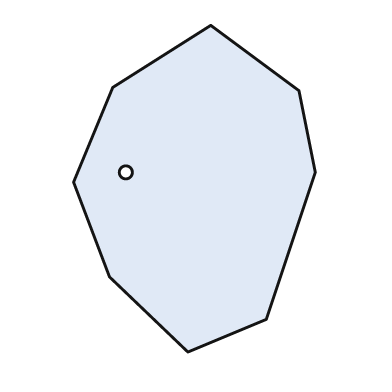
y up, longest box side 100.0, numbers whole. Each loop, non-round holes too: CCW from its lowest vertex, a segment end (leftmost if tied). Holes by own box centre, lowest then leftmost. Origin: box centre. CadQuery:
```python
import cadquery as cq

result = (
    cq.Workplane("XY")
    .moveTo(-2.0, -50.0)
    .lineTo(22.0, -40.0)
    .lineTo(37.0, 5.0)
    .lineTo(32.0, 30.0)
    .lineTo(5.0, 50.0)
    .lineTo(-25.0, 31.0)
    .lineTo(-37.0, 2.0)
    .lineTo(-26.0, -27.0)
    .close()
    .moveTo(-21.0, 5.0)
    .circle(2.0)
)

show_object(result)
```